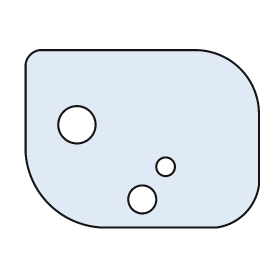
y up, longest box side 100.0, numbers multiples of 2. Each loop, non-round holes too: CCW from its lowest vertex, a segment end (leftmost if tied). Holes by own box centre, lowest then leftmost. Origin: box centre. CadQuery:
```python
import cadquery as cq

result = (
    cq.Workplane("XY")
    .moveTo(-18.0, -38.0)
    .lineTo(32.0, -38.0)
    .threePointArc((44.0, -32.0), (50.0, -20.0))
    .lineTo(50.0, 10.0)
    .threePointArc((42.0, 30.0), (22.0, 38.0))
    .lineTo(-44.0, 38.0)
    .threePointArc((-48.0, 36.0), (-50.0, 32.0))
    .lineTo(-50.0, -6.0)
    .threePointArc((-40.0, -28.0), (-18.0, -38.0))
    .close()
    .moveTo(0.0, -26.0)
    .circle(6.0)
    .moveTo(10.0, -12.0)
    .circle(4.0)
    .moveTo(-28.0, 6.0)
    .circle(8.0)
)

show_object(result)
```